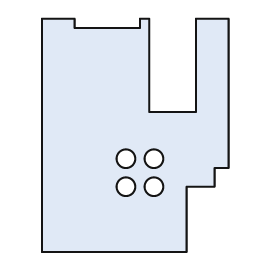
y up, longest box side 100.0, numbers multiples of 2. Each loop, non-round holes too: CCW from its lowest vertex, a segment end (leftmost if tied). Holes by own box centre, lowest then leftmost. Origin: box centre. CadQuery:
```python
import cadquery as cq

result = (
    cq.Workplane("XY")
    .moveTo(-40.0, -50.0)
    .lineTo(22.0, -50.0)
    .lineTo(22.0, -22.0)
    .lineTo(34.0, -22.0)
    .lineTo(34.0, -14.0)
    .lineTo(40.0, -14.0)
    .lineTo(40.0, 50.0)
    .lineTo(26.0, 50.0)
    .lineTo(26.0, 10.0)
    .lineTo(6.0, 10.0)
    .lineTo(6.0, 50.0)
    .lineTo(2.0, 50.0)
    .lineTo(2.0, 46.0)
    .lineTo(-26.0, 46.0)
    .lineTo(-26.0, 50.0)
    .lineTo(-40.0, 50.0)
    .close()
    .moveTo(-4.0, -22.0)
    .circle(4.0)
    .moveTo(8.0, -22.0)
    .circle(4.0)
    .moveTo(-4.0, -10.0)
    .circle(4.0)
    .moveTo(8.0, -10.0)
    .circle(4.0)
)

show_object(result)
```